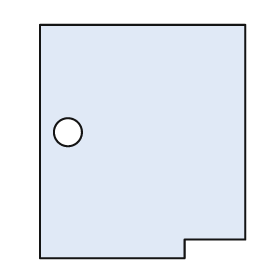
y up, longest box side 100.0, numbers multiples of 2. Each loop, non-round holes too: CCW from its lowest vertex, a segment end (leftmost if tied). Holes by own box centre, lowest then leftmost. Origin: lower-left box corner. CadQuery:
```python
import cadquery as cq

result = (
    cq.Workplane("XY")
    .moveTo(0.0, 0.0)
    .lineTo(62.0, 0.0)
    .lineTo(62.0, 8.0)
    .lineTo(88.0, 8.0)
    .lineTo(88.0, 100.0)
    .lineTo(0.0, 100.0)
    .close()
    .moveTo(12.0, 54.0)
    .circle(6.0)
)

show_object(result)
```